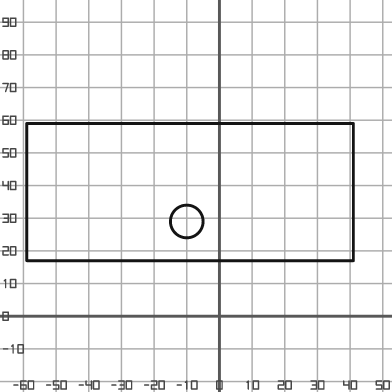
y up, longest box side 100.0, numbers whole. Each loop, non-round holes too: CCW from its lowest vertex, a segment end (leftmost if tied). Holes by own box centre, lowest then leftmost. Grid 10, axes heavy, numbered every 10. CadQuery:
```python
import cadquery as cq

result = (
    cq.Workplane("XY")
    .moveTo(-59.0, 17.0)
    .lineTo(41.0, 17.0)
    .lineTo(41.0, 59.0)
    .lineTo(-59.0, 59.0)
    .close()
    .moveTo(-10.0, 29.0)
    .circle(5.0)
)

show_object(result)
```